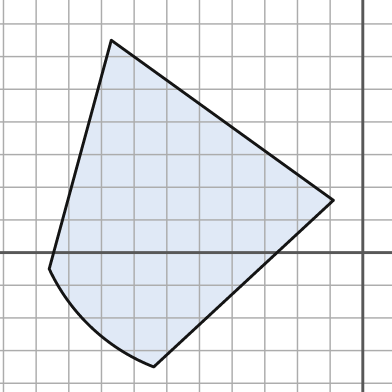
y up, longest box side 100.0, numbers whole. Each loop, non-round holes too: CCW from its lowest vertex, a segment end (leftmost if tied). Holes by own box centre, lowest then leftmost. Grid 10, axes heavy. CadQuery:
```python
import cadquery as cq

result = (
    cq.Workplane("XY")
    .moveTo(-64.0, -35.0)
    .lineTo(-9.0, 16.0)
    .lineTo(-77.0, 65.0)
    .lineTo(-96.0, -5.0)
    .threePointArc((-83.0, -23.0), (-64.0, -35.0))
    .close()
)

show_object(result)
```